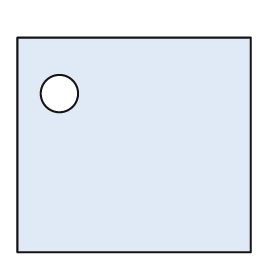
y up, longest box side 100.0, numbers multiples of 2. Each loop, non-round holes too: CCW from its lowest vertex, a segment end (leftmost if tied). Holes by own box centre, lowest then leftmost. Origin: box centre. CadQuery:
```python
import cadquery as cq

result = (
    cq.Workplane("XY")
    .moveTo(-50.0, -46.0)
    .lineTo(50.0, -46.0)
    .lineTo(50.0, 46.0)
    .lineTo(-50.0, 46.0)
    .close()
    .moveTo(-32.0, 22.0)
    .circle(8.0)
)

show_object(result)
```